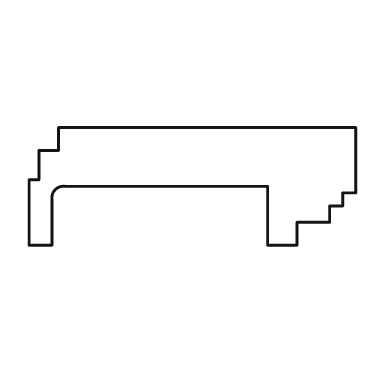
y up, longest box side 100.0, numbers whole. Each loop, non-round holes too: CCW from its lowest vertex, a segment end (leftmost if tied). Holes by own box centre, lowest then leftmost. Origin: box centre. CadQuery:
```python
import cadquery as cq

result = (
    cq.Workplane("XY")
    .moveTo(-50.0, -18.0)
    .lineTo(-43.0, -18.0)
    .lineTo(-43.0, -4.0)
    .threePointArc((-42.0, -1.0), (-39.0, 0.0))
    .lineTo(23.0, 0.0)
    .lineTo(23.0, -18.0)
    .lineTo(32.0, -18.0)
    .lineTo(32.0, -11.0)
    .lineTo(42.0, -11.0)
    .lineTo(42.0, -6.0)
    .lineTo(46.0, -6.0)
    .lineTo(46.0, -2.0)
    .lineTo(50.0, -2.0)
    .lineTo(50.0, 18.0)
    .lineTo(-41.0, 18.0)
    .lineTo(-41.0, 11.0)
    .lineTo(-47.0, 11.0)
    .lineTo(-47.0, 2.0)
    .lineTo(-50.0, 2.0)
    .close()
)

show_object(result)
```